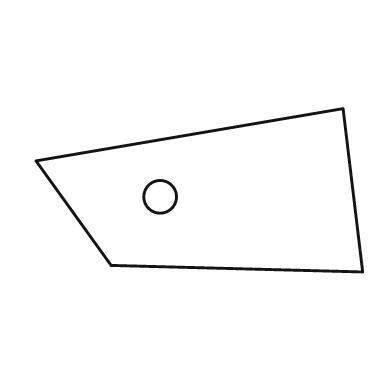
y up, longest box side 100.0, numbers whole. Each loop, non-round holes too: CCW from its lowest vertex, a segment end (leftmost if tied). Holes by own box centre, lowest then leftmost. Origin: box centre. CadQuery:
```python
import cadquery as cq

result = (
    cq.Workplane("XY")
    .moveTo(50.0, -25.0)
    .lineTo(44.0, 25.0)
    .lineTo(-50.0, 9.0)
    .lineTo(-27.0, -23.0)
    .close()
    .moveTo(-12.0, -2.0)
    .circle(5.0)
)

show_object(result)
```